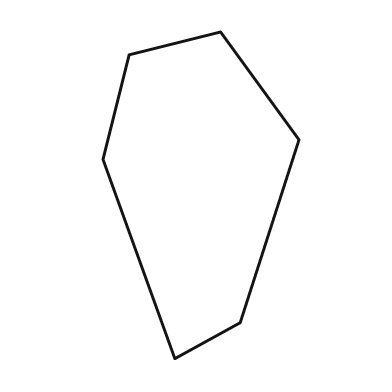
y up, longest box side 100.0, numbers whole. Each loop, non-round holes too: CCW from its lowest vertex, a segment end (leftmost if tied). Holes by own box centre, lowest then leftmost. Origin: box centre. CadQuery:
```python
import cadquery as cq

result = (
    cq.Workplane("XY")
    .moveTo(-8.0, -50.0)
    .lineTo(12.0, -39.0)
    .lineTo(30.0, 17.0)
    .lineTo(6.0, 50.0)
    .lineTo(-22.0, 43.0)
    .lineTo(-30.0, 11.0)
    .close()
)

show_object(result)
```